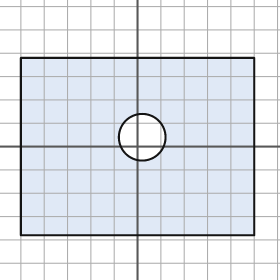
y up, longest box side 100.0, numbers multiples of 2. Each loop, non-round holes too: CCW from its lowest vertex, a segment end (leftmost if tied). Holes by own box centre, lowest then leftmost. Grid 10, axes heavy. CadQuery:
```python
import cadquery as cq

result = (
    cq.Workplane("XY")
    .moveTo(-50.0, -38.0)
    .lineTo(50.0, -38.0)
    .lineTo(50.0, 38.0)
    .lineTo(-50.0, 38.0)
    .close()
    .moveTo(2.0, 4.0)
    .circle(10.0)
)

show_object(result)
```